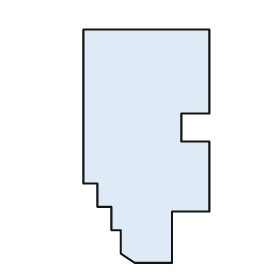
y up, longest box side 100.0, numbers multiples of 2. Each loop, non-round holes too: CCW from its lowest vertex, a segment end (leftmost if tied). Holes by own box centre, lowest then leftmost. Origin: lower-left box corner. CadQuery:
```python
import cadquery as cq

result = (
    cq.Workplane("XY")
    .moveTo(22.0, 0.0)
    .lineTo(38.0, 0.0)
    .lineTo(38.0, 22.0)
    .lineTo(54.0, 22.0)
    .lineTo(54.0, 52.0)
    .lineTo(42.0, 52.0)
    .lineTo(42.0, 64.0)
    .lineTo(54.0, 64.0)
    .lineTo(54.0, 100.0)
    .lineTo(0.0, 100.0)
    .lineTo(0.0, 34.0)
    .lineTo(6.0, 34.0)
    .lineTo(6.0, 24.0)
    .lineTo(12.0, 24.0)
    .lineTo(12.0, 14.0)
    .lineTo(16.0, 14.0)
    .lineTo(16.0, 4.0)
    .close()
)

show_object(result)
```